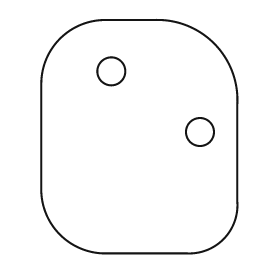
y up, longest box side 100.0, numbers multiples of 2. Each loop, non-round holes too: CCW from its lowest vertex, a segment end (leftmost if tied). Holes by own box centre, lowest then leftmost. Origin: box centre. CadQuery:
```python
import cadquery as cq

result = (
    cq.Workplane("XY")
    .moveTo(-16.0, -50.0)
    .lineTo(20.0, -50.0)
    .threePointArc((36.0, -44.0), (42.0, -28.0))
    .lineTo(42.0, 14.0)
    .threePointArc((32.0, 40.0), (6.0, 50.0))
    .lineTo(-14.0, 50.0)
    .threePointArc((-34.0, 42.0), (-42.0, 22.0))
    .lineTo(-42.0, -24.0)
    .threePointArc((-34.0, -42.0), (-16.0, -50.0))
    .close()
    .moveTo(26.0, 2.0)
    .circle(6.0)
    .moveTo(-12.0, 28.0)
    .circle(6.0)
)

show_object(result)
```